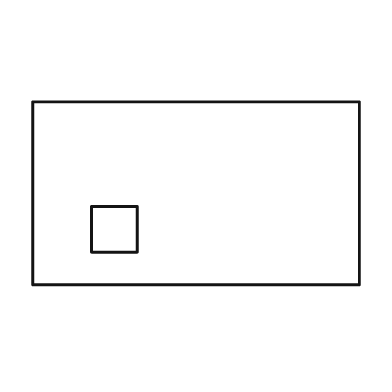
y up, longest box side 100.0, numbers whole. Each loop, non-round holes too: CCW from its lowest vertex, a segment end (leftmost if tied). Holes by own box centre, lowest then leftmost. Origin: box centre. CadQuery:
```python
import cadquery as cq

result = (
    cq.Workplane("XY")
    .moveTo(-50.0, -28.0)
    .lineTo(50.0, -28.0)
    .lineTo(50.0, 28.0)
    .lineTo(-50.0, 28.0)
    .close()
    .moveTo(-32.0, -18.0)
    .lineTo(-18.0, -18.0)
    .lineTo(-18.0, -4.0)
    .lineTo(-32.0, -4.0)
    .close()
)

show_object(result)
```